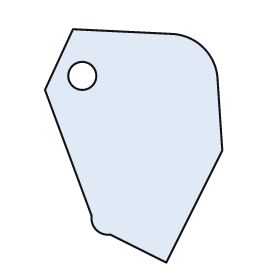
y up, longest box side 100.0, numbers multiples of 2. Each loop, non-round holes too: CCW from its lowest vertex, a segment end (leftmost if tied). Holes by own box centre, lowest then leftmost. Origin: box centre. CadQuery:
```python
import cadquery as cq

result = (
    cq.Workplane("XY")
    .moveTo(14.0, -50.0)
    .lineTo(38.0, -2.0)
    .lineTo(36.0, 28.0)
    .threePointArc((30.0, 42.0), (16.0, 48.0))
    .lineTo(-26.0, 50.0)
    .lineTo(-38.0, 24.0)
    .lineTo(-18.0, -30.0)
    .threePointArc((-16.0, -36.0), (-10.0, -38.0))
    .close()
    .moveTo(-22.0, 30.0)
    .circle(6.0)
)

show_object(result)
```